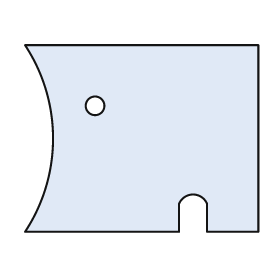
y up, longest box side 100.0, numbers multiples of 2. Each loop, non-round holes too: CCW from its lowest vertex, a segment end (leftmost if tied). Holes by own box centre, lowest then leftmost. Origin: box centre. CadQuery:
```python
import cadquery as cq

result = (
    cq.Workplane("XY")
    .moveTo(-50.0, -40.0)
    .lineTo(16.0, -40.0)
    .lineTo(16.0, -28.0)
    .threePointArc((22.0, -24.0), (28.0, -28.0))
    .lineTo(28.0, -40.0)
    .lineTo(50.0, -40.0)
    .lineTo(50.0, 40.0)
    .lineTo(-50.0, 40.0)
    .threePointArc((-38.0, 0.0), (-50.0, -40.0))
    .close()
    .moveTo(-20.0, 14.0)
    .circle(4.0)
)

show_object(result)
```